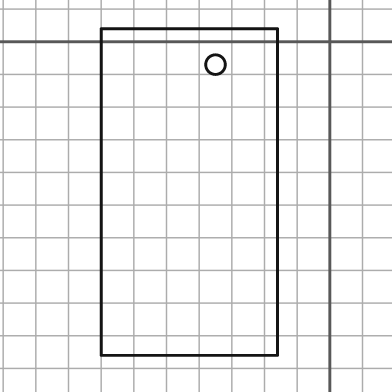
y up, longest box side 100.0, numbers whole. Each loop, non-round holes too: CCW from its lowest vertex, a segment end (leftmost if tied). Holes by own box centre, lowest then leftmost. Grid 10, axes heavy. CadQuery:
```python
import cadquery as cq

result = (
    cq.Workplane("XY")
    .moveTo(-70.0, -96.0)
    .lineTo(-16.0, -96.0)
    .lineTo(-16.0, 4.0)
    .lineTo(-70.0, 4.0)
    .close()
    .moveTo(-35.0, -7.0)
    .circle(3.0)
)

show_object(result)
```